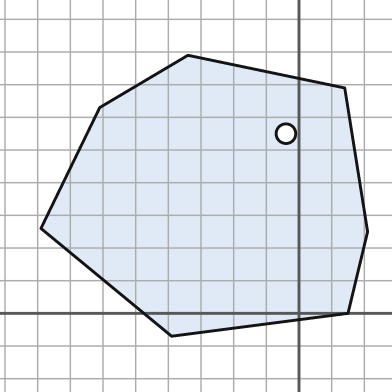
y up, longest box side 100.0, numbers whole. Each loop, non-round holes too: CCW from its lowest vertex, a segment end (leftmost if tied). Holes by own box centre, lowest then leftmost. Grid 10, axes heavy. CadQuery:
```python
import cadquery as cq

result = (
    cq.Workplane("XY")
    .moveTo(-39.0, -7.0)
    .lineTo(15.0, 0.0)
    .lineTo(21.0, 25.0)
    .lineTo(14.0, 69.0)
    .lineTo(-34.0, 79.0)
    .lineTo(-61.0, 63.0)
    .lineTo(-79.0, 26.0)
    .close()
    .moveTo(-4.0, 55.0)
    .circle(3.0)
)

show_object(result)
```